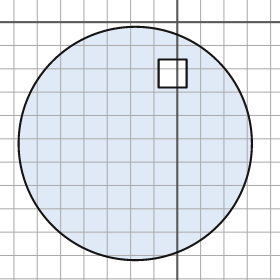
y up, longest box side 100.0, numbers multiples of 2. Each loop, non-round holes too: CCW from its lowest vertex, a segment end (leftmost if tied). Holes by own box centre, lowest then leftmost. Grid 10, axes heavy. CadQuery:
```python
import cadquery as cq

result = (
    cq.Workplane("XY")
    .moveTo(-18.0, -52.0)
    .circle(50.0)
    .moveTo(-8.0, -28.0)
    .lineTo(4.0, -28.0)
    .lineTo(4.0, -16.0)
    .lineTo(-8.0, -16.0)
    .close()
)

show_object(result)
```